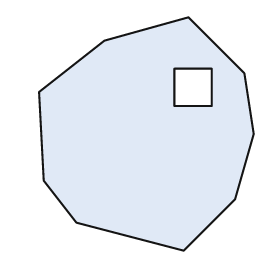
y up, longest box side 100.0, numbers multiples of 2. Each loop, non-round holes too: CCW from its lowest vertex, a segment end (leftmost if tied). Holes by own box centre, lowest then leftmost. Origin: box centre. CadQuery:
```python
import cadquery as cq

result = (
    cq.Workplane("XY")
    .moveTo(16.0, -50.0)
    .lineTo(38.0, -28.0)
    .lineTo(46.0, 0.0)
    .lineTo(42.0, 26.0)
    .lineTo(18.0, 50.0)
    .lineTo(-18.0, 40.0)
    .lineTo(-46.0, 18.0)
    .lineTo(-44.0, -20.0)
    .lineTo(-30.0, -38.0)
    .close()
    .moveTo(12.0, 12.0)
    .lineTo(28.0, 12.0)
    .lineTo(28.0, 28.0)
    .lineTo(12.0, 28.0)
    .close()
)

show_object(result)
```